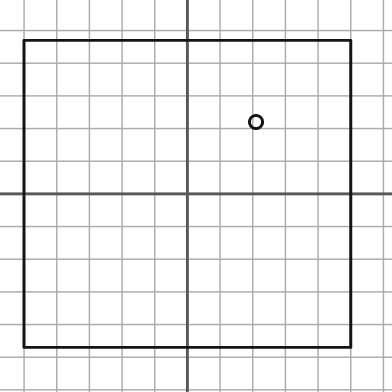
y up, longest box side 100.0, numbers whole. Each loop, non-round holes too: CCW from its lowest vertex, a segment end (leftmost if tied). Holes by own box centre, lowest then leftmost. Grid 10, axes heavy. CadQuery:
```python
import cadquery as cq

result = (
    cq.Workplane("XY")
    .moveTo(-50.0, -47.0)
    .lineTo(50.0, -47.0)
    .lineTo(50.0, 47.0)
    .lineTo(-50.0, 47.0)
    .close()
    .moveTo(21.0, 22.0)
    .circle(2.0)
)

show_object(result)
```